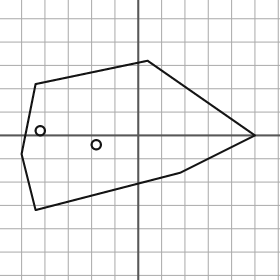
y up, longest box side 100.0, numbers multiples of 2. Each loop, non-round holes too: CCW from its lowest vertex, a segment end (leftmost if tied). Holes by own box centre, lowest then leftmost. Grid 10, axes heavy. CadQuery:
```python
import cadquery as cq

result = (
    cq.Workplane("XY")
    .moveTo(-44.0, -32.0)
    .lineTo(18.0, -16.0)
    .lineTo(50.0, 0.0)
    .lineTo(4.0, 32.0)
    .lineTo(-44.0, 22.0)
    .lineTo(-50.0, -8.0)
    .close()
    .moveTo(-18.0, -4.0)
    .circle(2.0)
    .moveTo(-42.0, 2.0)
    .circle(2.0)
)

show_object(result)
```